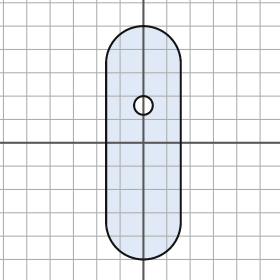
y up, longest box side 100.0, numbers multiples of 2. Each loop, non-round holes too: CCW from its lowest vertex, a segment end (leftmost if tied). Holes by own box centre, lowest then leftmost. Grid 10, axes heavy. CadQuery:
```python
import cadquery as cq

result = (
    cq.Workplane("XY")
    .moveTo(-16.0, -34.0)
    .threePointArc((0.0, -50.0), (16.0, -34.0))
    .lineTo(16.0, 34.0)
    .threePointArc((0.0, 50.0), (-16.0, 34.0))
    .close()
    .moveTo(0.0, 16.0)
    .circle(4.0)
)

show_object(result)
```